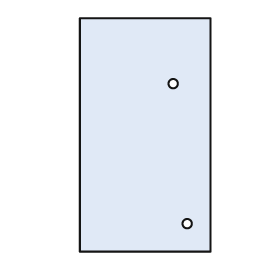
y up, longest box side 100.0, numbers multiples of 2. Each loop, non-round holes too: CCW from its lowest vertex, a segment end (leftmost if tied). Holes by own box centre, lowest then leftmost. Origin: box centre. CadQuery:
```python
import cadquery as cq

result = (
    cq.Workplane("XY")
    .moveTo(-28.0, -50.0)
    .lineTo(28.0, -50.0)
    .lineTo(28.0, 50.0)
    .lineTo(-28.0, 50.0)
    .close()
    .moveTo(18.0, -38.0)
    .circle(2.0)
    .moveTo(12.0, 22.0)
    .circle(2.0)
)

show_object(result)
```